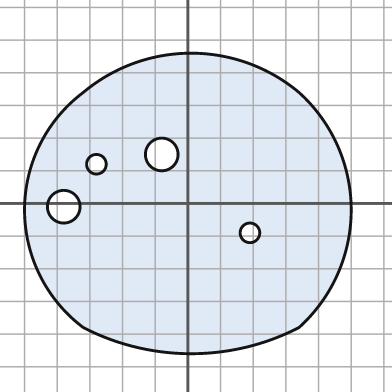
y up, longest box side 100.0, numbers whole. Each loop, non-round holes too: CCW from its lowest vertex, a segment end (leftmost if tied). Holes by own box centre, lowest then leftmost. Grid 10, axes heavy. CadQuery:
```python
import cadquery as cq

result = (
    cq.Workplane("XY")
    .moveTo(-32.0, -38.0)
    .threePointArc((1.0, -46.0), (34.0, -38.0))
    .threePointArc((50.0, -2.0), (34.0, 34.0))
    .threePointArc((1.0, 46.0), (-32.0, 34.0))
    .threePointArc((-50.0, -2.0), (-32.0, -38.0))
    .close()
    .moveTo(19.0, -9.0)
    .circle(3.0)
    .moveTo(-38.0, -1.0)
    .circle(5.0)
    .moveTo(-28.0, 12.0)
    .circle(3.0)
    .moveTo(-8.0, 15.0)
    .circle(5.0)
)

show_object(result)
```